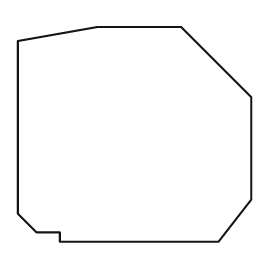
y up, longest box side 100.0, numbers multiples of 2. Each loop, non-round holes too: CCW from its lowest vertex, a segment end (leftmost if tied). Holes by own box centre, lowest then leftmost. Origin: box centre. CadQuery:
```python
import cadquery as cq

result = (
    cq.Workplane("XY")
    .moveTo(-32.0, -46.0)
    .lineTo(36.0, -46.0)
    .lineTo(50.0, -28.0)
    .lineTo(50.0, 16.0)
    .lineTo(20.0, 46.0)
    .lineTo(-16.0, 46.0)
    .lineTo(-50.0, 40.0)
    .lineTo(-50.0, -34.0)
    .lineTo(-42.0, -42.0)
    .lineTo(-32.0, -42.0)
    .close()
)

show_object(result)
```